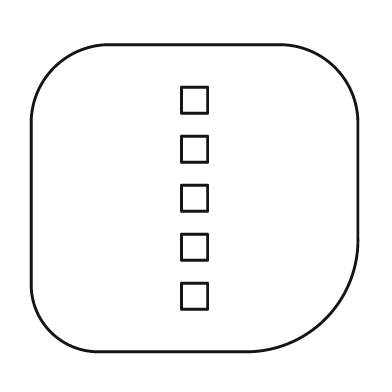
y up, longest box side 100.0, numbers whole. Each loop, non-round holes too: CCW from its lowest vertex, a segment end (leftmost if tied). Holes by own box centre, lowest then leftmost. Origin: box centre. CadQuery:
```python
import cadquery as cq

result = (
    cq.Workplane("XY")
    .moveTo(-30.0, -47.0)
    .lineTo(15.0, -47.0)
    .threePointArc((40.0, -37.0), (50.0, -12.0))
    .lineTo(50.0, 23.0)
    .threePointArc((43.0, 40.0), (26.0, 47.0))
    .lineTo(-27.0, 47.0)
    .threePointArc((-43.0, 40.0), (-50.0, 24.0))
    .lineTo(-50.0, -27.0)
    .threePointArc((-44.0, -41.0), (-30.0, -47.0))
    .close()
    .moveTo(-4.0, -34.0)
    .lineTo(4.0, -34.0)
    .lineTo(4.0, -26.0)
    .lineTo(-4.0, -26.0)
    .close()
    .moveTo(-4.0, -19.0)
    .lineTo(4.0, -19.0)
    .lineTo(4.0, -11.0)
    .lineTo(-4.0, -11.0)
    .close()
    .moveTo(-4.0, -4.0)
    .lineTo(4.0, -4.0)
    .lineTo(4.0, 4.0)
    .lineTo(-4.0, 4.0)
    .close()
    .moveTo(-4.0, 11.0)
    .lineTo(4.0, 11.0)
    .lineTo(4.0, 19.0)
    .lineTo(-4.0, 19.0)
    .close()
    .moveTo(-4.0, 26.0)
    .lineTo(4.0, 26.0)
    .lineTo(4.0, 34.0)
    .lineTo(-4.0, 34.0)
    .close()
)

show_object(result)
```